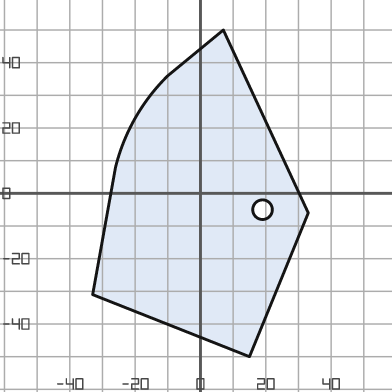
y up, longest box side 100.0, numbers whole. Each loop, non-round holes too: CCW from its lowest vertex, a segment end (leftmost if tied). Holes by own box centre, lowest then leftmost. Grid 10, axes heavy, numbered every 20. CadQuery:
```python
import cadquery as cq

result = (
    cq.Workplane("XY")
    .moveTo(15.0, -50.0)
    .lineTo(33.0, -6.0)
    .lineTo(7.0, 50.0)
    .lineTo(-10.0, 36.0)
    .threePointArc((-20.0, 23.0), (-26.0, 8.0))
    .lineTo(-33.0, -31.0)
    .close()
    .moveTo(19.0, -5.0)
    .circle(3.0)
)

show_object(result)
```